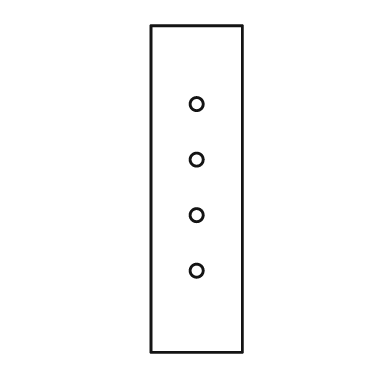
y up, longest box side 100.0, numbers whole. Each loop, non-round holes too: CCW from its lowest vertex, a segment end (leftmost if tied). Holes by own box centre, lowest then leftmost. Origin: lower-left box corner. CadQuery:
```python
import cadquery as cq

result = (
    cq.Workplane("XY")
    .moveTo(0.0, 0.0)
    .lineTo(28.0, 0.0)
    .lineTo(28.0, 100.0)
    .lineTo(0.0, 100.0)
    .close()
    .moveTo(14.0, 25.0)
    .circle(2.0)
    .moveTo(14.0, 42.0)
    .circle(2.0)
    .moveTo(14.0, 59.0)
    .circle(2.0)
    .moveTo(14.0, 76.0)
    .circle(2.0)
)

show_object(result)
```